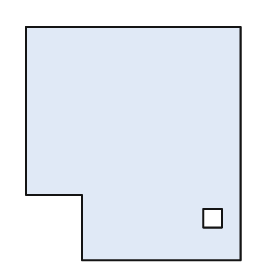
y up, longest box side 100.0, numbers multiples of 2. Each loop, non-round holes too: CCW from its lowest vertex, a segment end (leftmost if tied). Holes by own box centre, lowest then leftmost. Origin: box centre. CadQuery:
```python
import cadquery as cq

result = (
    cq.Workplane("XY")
    .moveTo(-22.0, -50.0)
    .lineTo(46.0, -50.0)
    .lineTo(46.0, 50.0)
    .lineTo(-46.0, 50.0)
    .lineTo(-46.0, -22.0)
    .lineTo(-22.0, -22.0)
    .close()
    .moveTo(30.0, -36.0)
    .lineTo(38.0, -36.0)
    .lineTo(38.0, -28.0)
    .lineTo(30.0, -28.0)
    .close()
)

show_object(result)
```